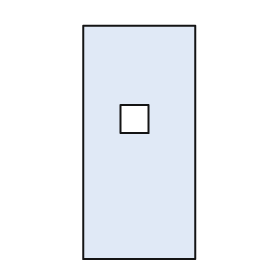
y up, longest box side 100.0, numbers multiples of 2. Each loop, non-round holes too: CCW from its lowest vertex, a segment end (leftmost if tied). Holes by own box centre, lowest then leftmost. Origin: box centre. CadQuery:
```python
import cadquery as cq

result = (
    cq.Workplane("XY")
    .moveTo(-24.0, -50.0)
    .lineTo(24.0, -50.0)
    .lineTo(24.0, 50.0)
    .lineTo(-24.0, 50.0)
    .close()
    .moveTo(-8.0, 4.0)
    .lineTo(4.0, 4.0)
    .lineTo(4.0, 16.0)
    .lineTo(-8.0, 16.0)
    .close()
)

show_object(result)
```